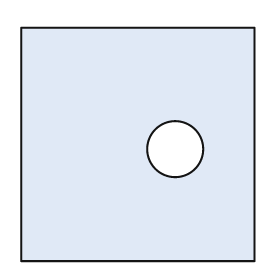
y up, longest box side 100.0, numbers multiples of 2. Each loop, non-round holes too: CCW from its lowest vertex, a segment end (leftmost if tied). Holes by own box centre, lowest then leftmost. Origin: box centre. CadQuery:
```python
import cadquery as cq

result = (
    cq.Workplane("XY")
    .moveTo(-50.0, -50.0)
    .lineTo(50.0, -50.0)
    .lineTo(50.0, 50.0)
    .lineTo(-50.0, 50.0)
    .close()
    .moveTo(16.0, -2.0)
    .circle(12.0)
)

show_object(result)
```